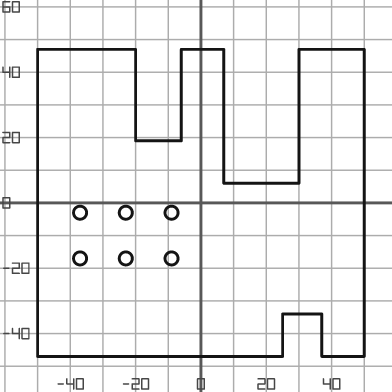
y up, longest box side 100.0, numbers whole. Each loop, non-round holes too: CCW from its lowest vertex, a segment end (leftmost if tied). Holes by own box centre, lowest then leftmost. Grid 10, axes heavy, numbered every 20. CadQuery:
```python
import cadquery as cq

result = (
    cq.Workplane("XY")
    .moveTo(-50.0, -47.0)
    .lineTo(25.0, -47.0)
    .lineTo(25.0, -34.0)
    .lineTo(37.0, -34.0)
    .lineTo(37.0, -47.0)
    .lineTo(50.0, -47.0)
    .lineTo(50.0, 47.0)
    .lineTo(30.0, 47.0)
    .lineTo(30.0, 6.0)
    .lineTo(7.0, 6.0)
    .lineTo(7.0, 47.0)
    .lineTo(-6.0, 47.0)
    .lineTo(-6.0, 19.0)
    .lineTo(-20.0, 19.0)
    .lineTo(-20.0, 47.0)
    .lineTo(-50.0, 47.0)
    .close()
    .moveTo(-37.0, -17.0)
    .circle(2.0)
    .moveTo(-23.0, -17.0)
    .circle(2.0)
    .moveTo(-9.0, -17.0)
    .circle(2.0)
    .moveTo(-37.0, -3.0)
    .circle(2.0)
    .moveTo(-23.0, -3.0)
    .circle(2.0)
    .moveTo(-9.0, -3.0)
    .circle(2.0)
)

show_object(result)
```